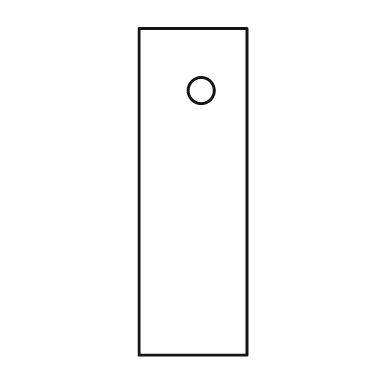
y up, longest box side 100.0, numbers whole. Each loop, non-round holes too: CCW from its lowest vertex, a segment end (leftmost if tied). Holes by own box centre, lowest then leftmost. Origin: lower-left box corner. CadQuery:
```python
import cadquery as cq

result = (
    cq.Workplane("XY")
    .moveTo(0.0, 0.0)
    .lineTo(33.0, 0.0)
    .lineTo(33.0, 100.0)
    .lineTo(0.0, 100.0)
    .close()
    .moveTo(19.0, 81.0)
    .circle(4.0)
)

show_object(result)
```